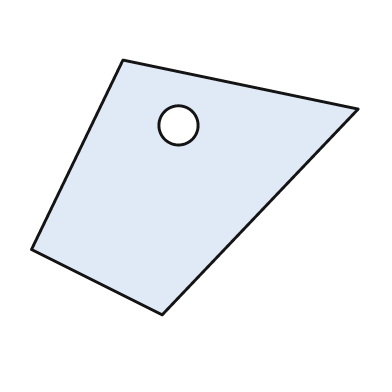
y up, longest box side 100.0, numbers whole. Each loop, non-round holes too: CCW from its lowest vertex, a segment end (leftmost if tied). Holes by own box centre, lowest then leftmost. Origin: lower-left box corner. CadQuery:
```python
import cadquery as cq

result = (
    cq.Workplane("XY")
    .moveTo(40.0, 0.0)
    .lineTo(100.0, 63.0)
    .lineTo(28.0, 78.0)
    .lineTo(0.0, 20.0)
    .close()
    .moveTo(45.0, 58.0)
    .circle(6.0)
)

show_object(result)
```